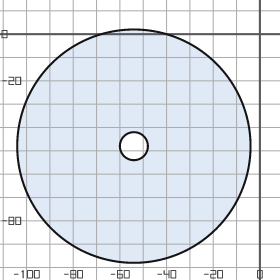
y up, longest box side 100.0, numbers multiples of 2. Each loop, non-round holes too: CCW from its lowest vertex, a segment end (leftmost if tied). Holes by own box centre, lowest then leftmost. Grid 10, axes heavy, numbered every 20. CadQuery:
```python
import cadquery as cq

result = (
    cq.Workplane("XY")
    .moveTo(-54.0, -48.0)
    .circle(50.0)
    .moveTo(-54.0, -48.0)
    .circle(6.0)
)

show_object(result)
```